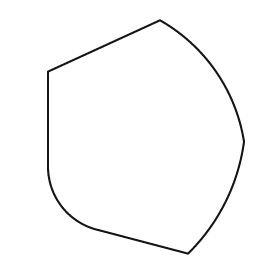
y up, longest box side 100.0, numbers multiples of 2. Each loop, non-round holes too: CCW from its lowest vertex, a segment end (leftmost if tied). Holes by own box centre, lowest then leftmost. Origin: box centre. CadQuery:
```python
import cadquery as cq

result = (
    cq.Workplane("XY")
    .moveTo(18.0, -50.0)
    .threePointArc((34.0, -28.0), (42.0, -2.0))
    .threePointArc((30.0, 28.0), (6.0, 50.0))
    .lineTo(-42.0, 28.0)
    .lineTo(-42.0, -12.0)
    .threePointArc((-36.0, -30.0), (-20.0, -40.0))
    .close()
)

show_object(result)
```